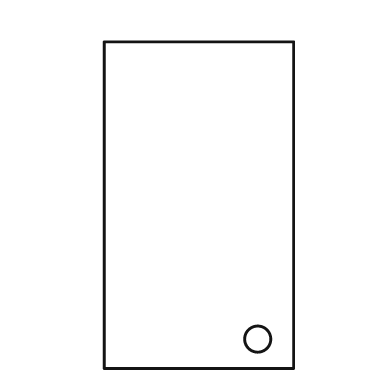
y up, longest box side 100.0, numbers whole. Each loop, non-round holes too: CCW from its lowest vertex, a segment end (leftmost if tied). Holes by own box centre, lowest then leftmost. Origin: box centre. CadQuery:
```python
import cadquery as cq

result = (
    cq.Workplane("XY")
    .moveTo(-29.0, -50.0)
    .lineTo(29.0, -50.0)
    .lineTo(29.0, 50.0)
    .lineTo(-29.0, 50.0)
    .close()
    .moveTo(18.0, -41.0)
    .circle(4.0)
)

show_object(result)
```